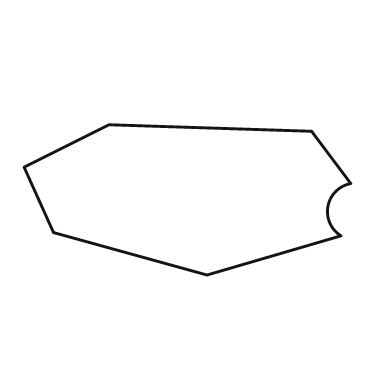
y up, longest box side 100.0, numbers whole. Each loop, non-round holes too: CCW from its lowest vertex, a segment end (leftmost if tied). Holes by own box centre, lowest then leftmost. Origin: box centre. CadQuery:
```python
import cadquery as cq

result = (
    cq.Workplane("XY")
    .moveTo(6.0, -23.0)
    .lineTo(47.0, -11.0)
    .threePointArc((43.0, -2.0), (50.0, 5.0))
    .lineTo(38.0, 21.0)
    .lineTo(-24.0, 23.0)
    .lineTo(-50.0, 10.0)
    .lineTo(-41.0, -10.0)
    .close()
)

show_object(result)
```